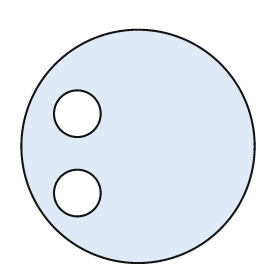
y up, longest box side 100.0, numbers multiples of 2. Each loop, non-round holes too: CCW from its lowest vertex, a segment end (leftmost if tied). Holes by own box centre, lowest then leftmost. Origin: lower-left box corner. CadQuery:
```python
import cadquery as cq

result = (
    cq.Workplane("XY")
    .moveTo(50.0, 50.0)
    .circle(50.0)
    .moveTo(24.0, 30.0)
    .circle(10.0)
    .moveTo(24.0, 64.0)
    .circle(10.0)
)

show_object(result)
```